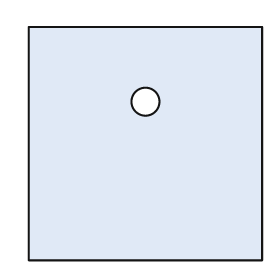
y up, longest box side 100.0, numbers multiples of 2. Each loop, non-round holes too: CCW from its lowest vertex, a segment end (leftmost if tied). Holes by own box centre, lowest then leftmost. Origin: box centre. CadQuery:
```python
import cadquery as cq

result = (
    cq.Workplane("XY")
    .moveTo(-50.0, -50.0)
    .lineTo(50.0, -50.0)
    .lineTo(50.0, 50.0)
    .lineTo(-50.0, 50.0)
    .close()
    .moveTo(0.0, 18.0)
    .circle(6.0)
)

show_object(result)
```